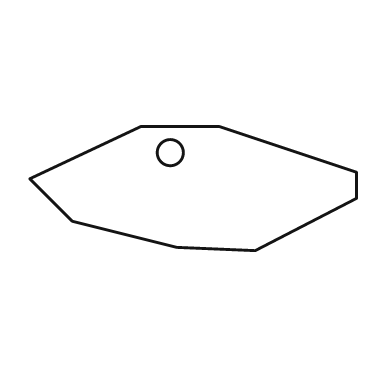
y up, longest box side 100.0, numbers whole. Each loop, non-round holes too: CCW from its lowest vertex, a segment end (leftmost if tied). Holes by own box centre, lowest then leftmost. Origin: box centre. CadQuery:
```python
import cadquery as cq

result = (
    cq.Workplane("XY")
    .moveTo(19.0, -19.0)
    .lineTo(50.0, -3.0)
    .lineTo(50.0, 5.0)
    .lineTo(8.0, 19.0)
    .lineTo(-16.0, 19.0)
    .lineTo(-50.0, 3.0)
    .lineTo(-37.0, -10.0)
    .lineTo(-5.0, -18.0)
    .close()
    .moveTo(-7.0, 11.0)
    .circle(4.0)
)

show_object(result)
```